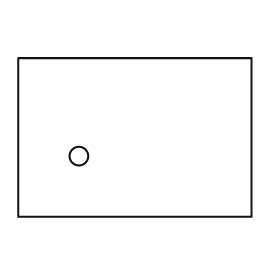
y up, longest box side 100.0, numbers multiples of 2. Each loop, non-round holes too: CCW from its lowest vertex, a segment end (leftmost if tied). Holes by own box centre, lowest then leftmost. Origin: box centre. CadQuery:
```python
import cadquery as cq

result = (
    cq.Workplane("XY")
    .moveTo(-50.0, -34.0)
    .lineTo(50.0, -34.0)
    .lineTo(50.0, 34.0)
    .lineTo(-50.0, 34.0)
    .close()
    .moveTo(-24.0, -8.0)
    .circle(4.0)
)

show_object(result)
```